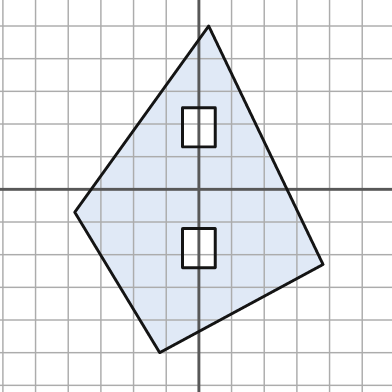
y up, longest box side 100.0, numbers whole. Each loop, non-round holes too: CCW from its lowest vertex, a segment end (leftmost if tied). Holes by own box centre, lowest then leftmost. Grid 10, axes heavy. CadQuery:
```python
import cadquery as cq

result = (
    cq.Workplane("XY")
    .moveTo(-12.0, -50.0)
    .lineTo(38.0, -23.0)
    .lineTo(3.0, 50.0)
    .lineTo(-38.0, -7.0)
    .close()
    .moveTo(-5.0, -24.0)
    .lineTo(5.0, -24.0)
    .lineTo(5.0, -12.0)
    .lineTo(-5.0, -12.0)
    .close()
    .moveTo(-5.0, 13.0)
    .lineTo(5.0, 13.0)
    .lineTo(5.0, 25.0)
    .lineTo(-5.0, 25.0)
    .close()
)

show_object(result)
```